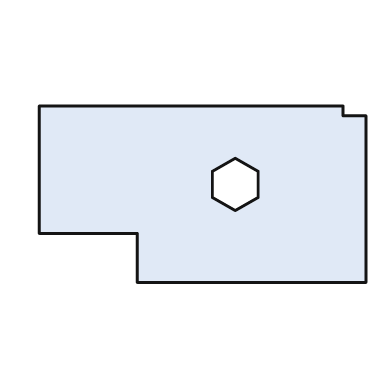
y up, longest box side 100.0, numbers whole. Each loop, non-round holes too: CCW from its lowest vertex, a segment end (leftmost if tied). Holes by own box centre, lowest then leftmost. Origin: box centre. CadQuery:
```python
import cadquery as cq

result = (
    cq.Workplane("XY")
    .moveTo(-20.0, -27.0)
    .lineTo(50.0, -27.0)
    .lineTo(50.0, 24.0)
    .lineTo(43.0, 24.0)
    .lineTo(43.0, 27.0)
    .lineTo(-50.0, 27.0)
    .lineTo(-50.0, -12.0)
    .lineTo(-20.0, -12.0)
    .close()
    .moveTo(10.0, -5.0)
    .lineTo(17.0, -1.0)
    .lineTo(17.0, 7.0)
    .lineTo(10.0, 11.0)
    .lineTo(3.0, 7.0)
    .lineTo(3.0, -1.0)
    .close()
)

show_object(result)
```